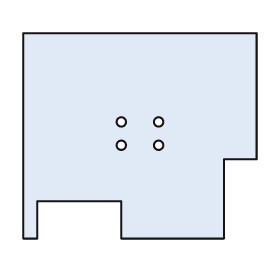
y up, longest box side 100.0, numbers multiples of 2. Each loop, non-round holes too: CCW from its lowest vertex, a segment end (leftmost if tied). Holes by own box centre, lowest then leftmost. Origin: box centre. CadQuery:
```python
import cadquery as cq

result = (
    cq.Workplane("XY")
    .moveTo(-50.0, -44.0)
    .lineTo(-44.0, -44.0)
    .lineTo(-44.0, -28.0)
    .lineTo(-8.0, -28.0)
    .lineTo(-8.0, -44.0)
    .lineTo(36.0, -44.0)
    .lineTo(36.0, -10.0)
    .lineTo(50.0, -10.0)
    .lineTo(50.0, 44.0)
    .lineTo(-50.0, 44.0)
    .close()
    .moveTo(-8.0, -4.0)
    .circle(2.0)
    .moveTo(8.0, -4.0)
    .circle(2.0)
    .moveTo(-8.0, 6.0)
    .circle(2.0)
    .moveTo(8.0, 6.0)
    .circle(2.0)
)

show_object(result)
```